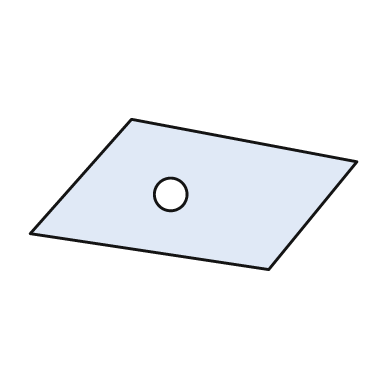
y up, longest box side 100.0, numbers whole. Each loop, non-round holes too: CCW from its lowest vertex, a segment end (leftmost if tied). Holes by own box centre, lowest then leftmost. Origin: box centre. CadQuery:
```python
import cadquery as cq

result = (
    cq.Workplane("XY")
    .moveTo(23.0, -23.0)
    .lineTo(50.0, 10.0)
    .lineTo(-19.0, 23.0)
    .lineTo(-50.0, -12.0)
    .close()
    .moveTo(-7.0, 0.0)
    .circle(5.0)
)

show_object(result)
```